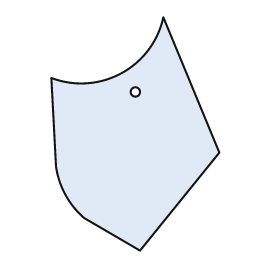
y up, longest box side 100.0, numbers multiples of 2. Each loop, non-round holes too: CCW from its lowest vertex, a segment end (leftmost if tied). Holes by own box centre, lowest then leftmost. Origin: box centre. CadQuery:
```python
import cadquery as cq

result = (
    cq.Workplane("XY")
    .moveTo(2.0, -50.0)
    .lineTo(36.0, -8.0)
    .lineTo(12.0, 50.0)
    .threePointArc((-6.0, 26.0), (-36.0, 24.0))
    .lineTo(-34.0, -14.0)
    .threePointArc((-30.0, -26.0), (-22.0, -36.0))
    .close()
    .moveTo(0.0, 18.0)
    .circle(2.0)
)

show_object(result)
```